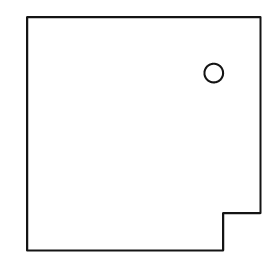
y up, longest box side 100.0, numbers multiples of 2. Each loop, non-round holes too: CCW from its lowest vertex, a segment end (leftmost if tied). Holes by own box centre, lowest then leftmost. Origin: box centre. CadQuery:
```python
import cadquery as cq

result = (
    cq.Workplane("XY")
    .moveTo(-50.0, -50.0)
    .lineTo(34.0, -50.0)
    .lineTo(34.0, -34.0)
    .lineTo(50.0, -34.0)
    .lineTo(50.0, 50.0)
    .lineTo(-50.0, 50.0)
    .close()
    .moveTo(30.0, 26.0)
    .circle(4.0)
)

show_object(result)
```